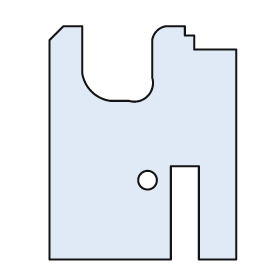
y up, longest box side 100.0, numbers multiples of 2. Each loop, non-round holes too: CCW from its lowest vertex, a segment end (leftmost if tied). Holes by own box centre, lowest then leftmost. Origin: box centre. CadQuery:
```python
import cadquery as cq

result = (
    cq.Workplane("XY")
    .moveTo(-40.0, -50.0)
    .lineTo(12.0, -50.0)
    .lineTo(12.0, -10.0)
    .lineTo(24.0, -10.0)
    .lineTo(24.0, -50.0)
    .lineTo(40.0, -50.0)
    .lineTo(40.0, 40.0)
    .lineTo(22.0, 40.0)
    .lineTo(22.0, 46.0)
    .lineTo(18.0, 46.0)
    .lineTo(18.0, 50.0)
    .lineTo(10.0, 50.0)
    .threePointArc((6.0, 48.0), (4.0, 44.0))
    .lineTo(4.0, 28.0)
    .threePointArc((2.0, 20.0), (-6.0, 18.0))
    .lineTo(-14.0, 18.0)
    .threePointArc((-22.0, 22.0), (-26.0, 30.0))
    .lineTo(-26.0, 50.0)
    .lineTo(-34.0, 50.0)
    .lineTo(-40.0, 44.0)
    .close()
    .moveTo(2.0, -16.0)
    .circle(4.0)
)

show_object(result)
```